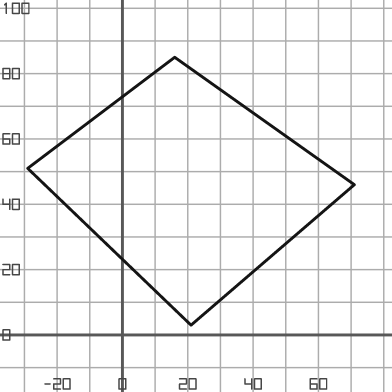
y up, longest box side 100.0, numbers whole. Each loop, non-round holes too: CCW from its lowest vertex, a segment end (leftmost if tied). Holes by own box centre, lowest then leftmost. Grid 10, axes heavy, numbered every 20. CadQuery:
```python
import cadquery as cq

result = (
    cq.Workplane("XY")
    .moveTo(21.0, 3.0)
    .lineTo(71.0, 46.0)
    .lineTo(16.0, 85.0)
    .lineTo(-29.0, 51.0)
    .close()
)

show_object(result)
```